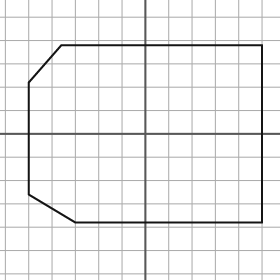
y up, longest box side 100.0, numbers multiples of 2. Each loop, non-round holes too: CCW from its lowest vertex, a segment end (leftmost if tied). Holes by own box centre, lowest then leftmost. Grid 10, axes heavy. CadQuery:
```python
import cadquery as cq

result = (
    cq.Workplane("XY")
    .moveTo(-30.0, -38.0)
    .lineTo(50.0, -38.0)
    .lineTo(50.0, 38.0)
    .lineTo(-36.0, 38.0)
    .lineTo(-50.0, 22.0)
    .lineTo(-50.0, -26.0)
    .close()
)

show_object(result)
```